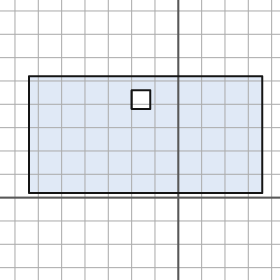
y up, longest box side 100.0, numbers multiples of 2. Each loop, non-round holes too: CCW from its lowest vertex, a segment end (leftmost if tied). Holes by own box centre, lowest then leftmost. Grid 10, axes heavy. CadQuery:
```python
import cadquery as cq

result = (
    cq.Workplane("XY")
    .moveTo(-64.0, 2.0)
    .lineTo(36.0, 2.0)
    .lineTo(36.0, 52.0)
    .lineTo(-64.0, 52.0)
    .close()
    .moveTo(-20.0, 38.0)
    .lineTo(-12.0, 38.0)
    .lineTo(-12.0, 46.0)
    .lineTo(-20.0, 46.0)
    .close()
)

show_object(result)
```